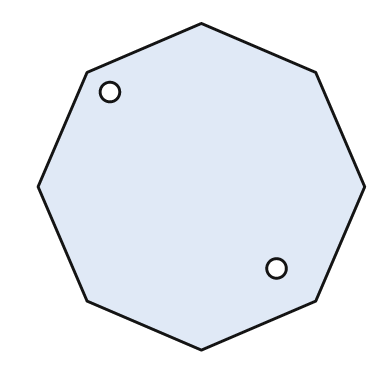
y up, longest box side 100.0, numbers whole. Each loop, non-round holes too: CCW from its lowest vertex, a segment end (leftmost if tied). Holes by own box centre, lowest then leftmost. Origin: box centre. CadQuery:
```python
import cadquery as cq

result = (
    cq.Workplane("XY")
    .moveTo(0.0, -50.0)
    .lineTo(35.0, -35.0)
    .lineTo(50.0, 0.0)
    .lineTo(35.0, 35.0)
    .lineTo(0.0, 50.0)
    .lineTo(-35.0, 35.0)
    .lineTo(-50.0, 0.0)
    .lineTo(-35.0, -35.0)
    .close()
    .moveTo(23.0, -25.0)
    .circle(3.0)
    .moveTo(-28.0, 29.0)
    .circle(3.0)
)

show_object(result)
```